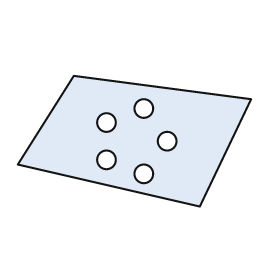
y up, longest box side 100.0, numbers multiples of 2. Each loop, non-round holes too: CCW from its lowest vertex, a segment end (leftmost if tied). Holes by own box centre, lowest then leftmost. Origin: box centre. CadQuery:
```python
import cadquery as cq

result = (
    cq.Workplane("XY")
    .moveTo(28.0, -28.0)
    .lineTo(50.0, 18.0)
    .lineTo(-26.0, 28.0)
    .lineTo(-50.0, -10.0)
    .close()
    .moveTo(4.0, -14.0)
    .circle(4.0)
    .moveTo(-12.0, -8.0)
    .circle(4.0)
    .moveTo(14.0, 0.0)
    .circle(4.0)
    .moveTo(-12.0, 8.0)
    .circle(4.0)
    .moveTo(4.0, 14.0)
    .circle(4.0)
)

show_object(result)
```